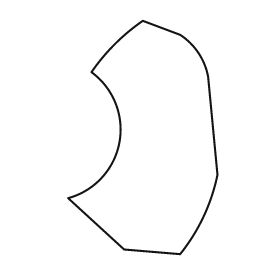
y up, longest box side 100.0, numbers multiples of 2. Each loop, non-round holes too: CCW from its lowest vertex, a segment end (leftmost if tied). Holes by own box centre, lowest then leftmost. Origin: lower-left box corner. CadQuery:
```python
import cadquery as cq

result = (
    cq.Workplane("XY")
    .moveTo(48.0, 0.0)
    .threePointArc((58.0, 16.0), (64.0, 34.0))
    .lineTo(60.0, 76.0)
    .threePointArc((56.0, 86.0), (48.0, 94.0))
    .lineTo(32.0, 100.0)
    .threePointArc((20.0, 90.0), (10.0, 78.0))
    .threePointArc((22.0, 48.0), (0.0, 24.0))
    .lineTo(24.0, 2.0)
    .close()
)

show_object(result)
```